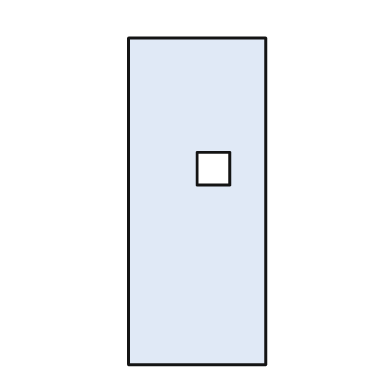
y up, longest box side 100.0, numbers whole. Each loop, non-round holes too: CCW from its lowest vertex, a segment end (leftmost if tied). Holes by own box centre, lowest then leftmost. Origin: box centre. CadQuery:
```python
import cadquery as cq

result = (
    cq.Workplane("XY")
    .moveTo(-21.0, -50.0)
    .lineTo(21.0, -50.0)
    .lineTo(21.0, 50.0)
    .lineTo(-21.0, 50.0)
    .close()
    .moveTo(0.0, 5.0)
    .lineTo(10.0, 5.0)
    .lineTo(10.0, 15.0)
    .lineTo(0.0, 15.0)
    .close()
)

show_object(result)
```